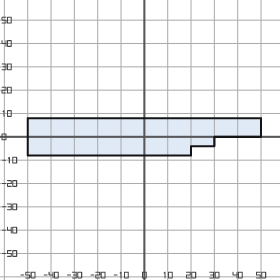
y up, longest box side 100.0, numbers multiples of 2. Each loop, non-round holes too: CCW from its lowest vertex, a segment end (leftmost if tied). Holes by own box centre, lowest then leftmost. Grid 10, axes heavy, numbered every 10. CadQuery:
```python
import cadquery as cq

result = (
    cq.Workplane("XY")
    .moveTo(-50.0, -8.0)
    .lineTo(20.0, -8.0)
    .lineTo(20.0, -4.0)
    .lineTo(30.0, -4.0)
    .lineTo(30.0, 0.0)
    .lineTo(50.0, 0.0)
    .lineTo(50.0, 8.0)
    .lineTo(-50.0, 8.0)
    .close()
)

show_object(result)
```